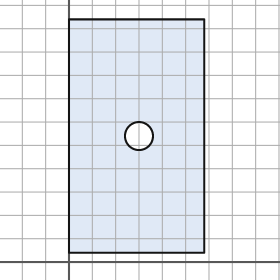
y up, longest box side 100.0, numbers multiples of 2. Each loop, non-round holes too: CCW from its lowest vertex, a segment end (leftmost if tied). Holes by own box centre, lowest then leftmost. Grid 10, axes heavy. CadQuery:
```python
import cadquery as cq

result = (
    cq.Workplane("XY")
    .moveTo(0.0, 4.0)
    .lineTo(58.0, 4.0)
    .lineTo(58.0, 104.0)
    .lineTo(0.0, 104.0)
    .close()
    .moveTo(30.0, 54.0)
    .circle(6.0)
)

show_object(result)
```